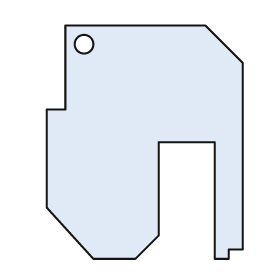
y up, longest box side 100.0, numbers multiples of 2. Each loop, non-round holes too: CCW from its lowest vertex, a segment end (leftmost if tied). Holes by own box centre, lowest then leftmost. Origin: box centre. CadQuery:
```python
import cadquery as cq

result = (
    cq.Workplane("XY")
    .moveTo(-22.0, -50.0)
    .lineTo(-4.0, -50.0)
    .lineTo(6.0, -40.0)
    .lineTo(6.0, 0.0)
    .lineTo(30.0, 0.0)
    .lineTo(30.0, -50.0)
    .lineTo(36.0, -50.0)
    .lineTo(36.0, -46.0)
    .lineTo(42.0, -46.0)
    .lineTo(42.0, 34.0)
    .lineTo(26.0, 50.0)
    .lineTo(-34.0, 50.0)
    .lineTo(-34.0, 14.0)
    .lineTo(-42.0, 14.0)
    .lineTo(-42.0, -28.0)
    .close()
    .moveTo(-26.0, 42.0)
    .circle(4.0)
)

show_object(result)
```